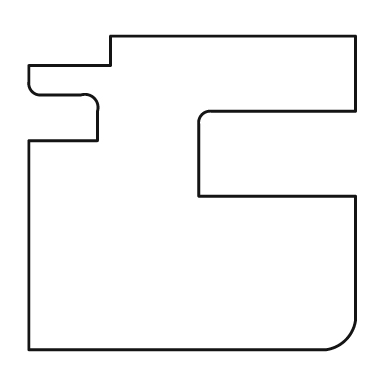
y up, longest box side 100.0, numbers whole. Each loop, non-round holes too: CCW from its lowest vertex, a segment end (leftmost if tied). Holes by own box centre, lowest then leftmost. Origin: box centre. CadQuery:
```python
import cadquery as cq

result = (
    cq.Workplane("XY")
    .moveTo(-50.0, -48.0)
    .lineTo(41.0, -48.0)
    .threePointArc((47.0, -45.0), (50.0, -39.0))
    .lineTo(50.0, -1.0)
    .lineTo(2.0, -1.0)
    .lineTo(2.0, 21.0)
    .threePointArc((3.0, 24.0), (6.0, 25.0))
    .lineTo(50.0, 25.0)
    .lineTo(50.0, 48.0)
    .lineTo(-25.0, 48.0)
    .lineTo(-25.0, 39.0)
    .lineTo(-50.0, 39.0)
    .lineTo(-50.0, 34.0)
    .threePointArc((-49.0, 31.0), (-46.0, 30.0))
    .lineTo(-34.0, 30.0)
    .threePointArc((-30.0, 29.0), (-29.0, 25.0))
    .lineTo(-29.0, 16.0)
    .lineTo(-50.0, 16.0)
    .close()
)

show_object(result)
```